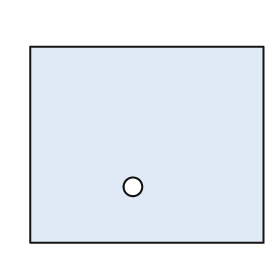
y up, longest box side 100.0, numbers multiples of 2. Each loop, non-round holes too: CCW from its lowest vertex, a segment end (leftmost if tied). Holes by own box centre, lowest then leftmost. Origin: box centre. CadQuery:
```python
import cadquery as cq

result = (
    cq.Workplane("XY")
    .moveTo(-50.0, -42.0)
    .lineTo(50.0, -42.0)
    .lineTo(50.0, 42.0)
    .lineTo(-50.0, 42.0)
    .close()
    .moveTo(-6.0, -18.0)
    .circle(4.0)
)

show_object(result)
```